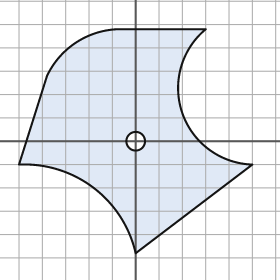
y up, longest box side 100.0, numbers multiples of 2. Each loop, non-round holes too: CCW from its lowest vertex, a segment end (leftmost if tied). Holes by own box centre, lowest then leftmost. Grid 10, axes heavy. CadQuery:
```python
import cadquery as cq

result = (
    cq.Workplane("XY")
    .moveTo(0.0, -48.0)
    .lineTo(50.0, -10.0)
    .threePointArc((20.0, 12.0), (30.0, 48.0))
    .lineTo(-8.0, 48.0)
    .threePointArc((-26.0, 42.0), (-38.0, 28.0))
    .lineTo(-50.0, -10.0)
    .threePointArc((-18.0, -20.0), (0.0, -48.0))
    .close()
    .moveTo(0.0, 0.0)
    .circle(4.0)
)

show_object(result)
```